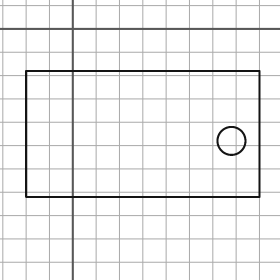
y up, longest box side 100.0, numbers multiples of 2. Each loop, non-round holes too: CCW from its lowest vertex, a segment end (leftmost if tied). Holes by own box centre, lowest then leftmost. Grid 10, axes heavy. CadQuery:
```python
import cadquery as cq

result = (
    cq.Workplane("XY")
    .moveTo(-20.0, -72.0)
    .lineTo(80.0, -72.0)
    .lineTo(80.0, -18.0)
    .lineTo(-20.0, -18.0)
    .close()
    .moveTo(68.0, -48.0)
    .circle(6.0)
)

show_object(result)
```